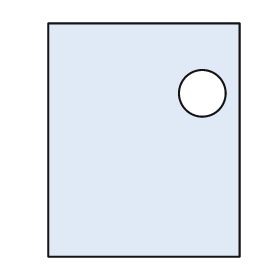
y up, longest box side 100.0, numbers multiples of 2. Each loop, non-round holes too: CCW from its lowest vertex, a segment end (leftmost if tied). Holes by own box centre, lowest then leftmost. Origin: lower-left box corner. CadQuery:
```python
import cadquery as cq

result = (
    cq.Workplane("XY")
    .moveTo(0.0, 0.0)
    .lineTo(82.0, 0.0)
    .lineTo(82.0, 100.0)
    .lineTo(0.0, 100.0)
    .close()
    .moveTo(66.0, 70.0)
    .circle(10.0)
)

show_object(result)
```